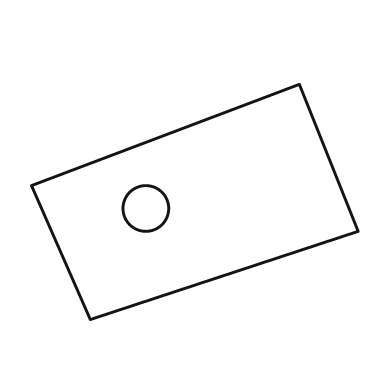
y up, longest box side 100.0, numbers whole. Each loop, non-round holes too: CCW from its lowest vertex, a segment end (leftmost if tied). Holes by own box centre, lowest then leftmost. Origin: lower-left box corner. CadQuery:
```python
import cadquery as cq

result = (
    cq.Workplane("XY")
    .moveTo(18.0, 0.0)
    .lineTo(100.0, 27.0)
    .lineTo(82.0, 72.0)
    .lineTo(0.0, 41.0)
    .close()
    .moveTo(35.0, 34.0)
    .circle(7.0)
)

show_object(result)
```